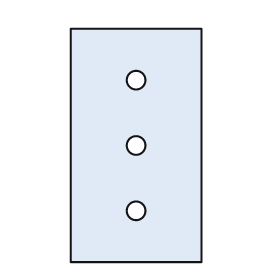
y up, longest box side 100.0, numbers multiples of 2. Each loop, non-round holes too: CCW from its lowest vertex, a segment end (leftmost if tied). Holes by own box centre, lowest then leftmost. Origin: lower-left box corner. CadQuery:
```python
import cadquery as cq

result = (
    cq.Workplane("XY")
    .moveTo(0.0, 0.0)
    .lineTo(56.0, 0.0)
    .lineTo(56.0, 100.0)
    .lineTo(0.0, 100.0)
    .close()
    .moveTo(28.0, 22.0)
    .circle(4.0)
    .moveTo(28.0, 50.0)
    .circle(4.0)
    .moveTo(28.0, 78.0)
    .circle(4.0)
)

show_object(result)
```